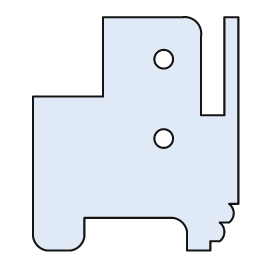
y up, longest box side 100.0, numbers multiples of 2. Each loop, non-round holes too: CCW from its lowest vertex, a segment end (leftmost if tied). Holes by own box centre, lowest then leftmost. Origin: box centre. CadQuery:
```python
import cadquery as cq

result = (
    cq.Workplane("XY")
    .moveTo(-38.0, -50.0)
    .lineTo(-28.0, -50.0)
    .threePointArc((-24.0, -48.0), (-22.0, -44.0))
    .lineTo(-22.0, -36.0)
    .lineTo(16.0, -36.0)
    .threePointArc((20.0, -38.0), (22.0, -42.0))
    .lineTo(22.0, -50.0)
    .lineTo(32.0, -50.0)
    .lineTo(32.0, -46.0)
    .lineTo(36.0, -46.0)
    .threePointArc((38.0, -42.0), (36.0, -38.0))
    .lineTo(40.0, -38.0)
    .threePointArc((42.0, -34.0), (40.0, -30.0))
    .lineTo(44.0, -30.0)
    .lineTo(44.0, 50.0)
    .lineTo(38.0, 50.0)
    .lineTo(38.0, 8.0)
    .lineTo(28.0, 8.0)
    .lineTo(28.0, 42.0)
    .threePointArc((26.0, 48.0), (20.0, 50.0))
    .lineTo(-14.0, 50.0)
    .lineTo(-14.0, 16.0)
    .lineTo(-44.0, 16.0)
    .lineTo(-44.0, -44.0)
    .threePointArc((-42.0, -48.0), (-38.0, -50.0))
    .close()
    .moveTo(12.0, -2.0)
    .circle(4.0)
    .moveTo(12.0, 32.0)
    .circle(4.0)
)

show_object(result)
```